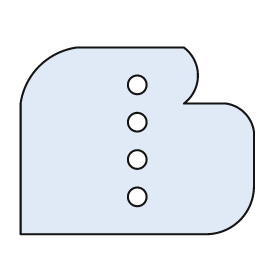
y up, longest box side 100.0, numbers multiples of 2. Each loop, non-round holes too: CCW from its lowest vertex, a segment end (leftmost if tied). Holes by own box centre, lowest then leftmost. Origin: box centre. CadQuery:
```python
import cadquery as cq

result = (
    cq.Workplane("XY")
    .moveTo(-50.0, -40.0)
    .lineTo(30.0, -40.0)
    .threePointArc((44.0, -34.0), (50.0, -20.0))
    .lineTo(50.0, 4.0)
    .threePointArc((46.0, 12.0), (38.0, 16.0))
    .lineTo(20.0, 16.0)
    .threePointArc((26.0, 28.0), (20.0, 40.0))
    .lineTo(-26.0, 40.0)
    .threePointArc((-42.0, 32.0), (-50.0, 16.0))
    .close()
    .moveTo(0.0, -24.0)
    .circle(4.0)
    .moveTo(0.0, -8.0)
    .circle(4.0)
    .moveTo(0.0, 8.0)
    .circle(4.0)
    .moveTo(0.0, 24.0)
    .circle(4.0)
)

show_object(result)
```